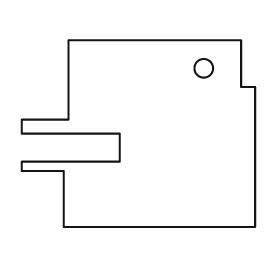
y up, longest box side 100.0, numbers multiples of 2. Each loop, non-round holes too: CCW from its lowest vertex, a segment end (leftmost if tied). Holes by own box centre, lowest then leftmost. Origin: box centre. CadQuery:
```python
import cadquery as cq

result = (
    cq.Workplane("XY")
    .moveTo(-32.0, -40.0)
    .lineTo(50.0, -40.0)
    .lineTo(50.0, 20.0)
    .lineTo(44.0, 20.0)
    .lineTo(44.0, 40.0)
    .lineTo(-30.0, 40.0)
    .lineTo(-30.0, 6.0)
    .lineTo(-50.0, 6.0)
    .lineTo(-50.0, 0.0)
    .lineTo(-8.0, 0.0)
    .lineTo(-8.0, -12.0)
    .lineTo(-50.0, -12.0)
    .lineTo(-50.0, -16.0)
    .lineTo(-32.0, -16.0)
    .close()
    .moveTo(28.0, 28.0)
    .circle(4.0)
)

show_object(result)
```